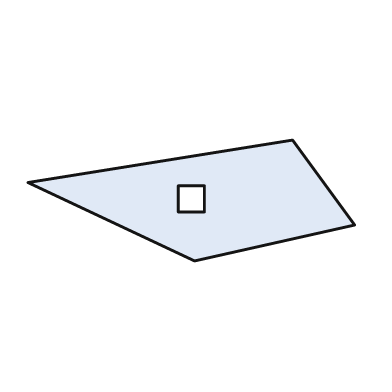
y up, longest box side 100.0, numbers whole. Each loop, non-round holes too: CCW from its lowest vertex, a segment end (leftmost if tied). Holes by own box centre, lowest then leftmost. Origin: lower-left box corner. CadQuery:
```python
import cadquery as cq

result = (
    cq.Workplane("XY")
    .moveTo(51.0, 0.0)
    .lineTo(100.0, 11.0)
    .lineTo(81.0, 37.0)
    .lineTo(0.0, 24.0)
    .close()
    .moveTo(46.0, 15.0)
    .lineTo(54.0, 15.0)
    .lineTo(54.0, 23.0)
    .lineTo(46.0, 23.0)
    .close()
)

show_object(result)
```